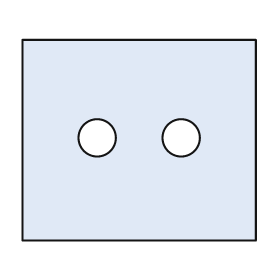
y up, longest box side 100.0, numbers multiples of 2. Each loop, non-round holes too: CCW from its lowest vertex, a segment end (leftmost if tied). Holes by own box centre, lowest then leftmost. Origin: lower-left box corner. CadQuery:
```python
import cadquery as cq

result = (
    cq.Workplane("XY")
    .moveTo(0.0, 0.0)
    .lineTo(100.0, 0.0)
    .lineTo(100.0, 86.0)
    .lineTo(0.0, 86.0)
    .close()
    .moveTo(32.0, 44.0)
    .circle(8.0)
    .moveTo(68.0, 44.0)
    .circle(8.0)
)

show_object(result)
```